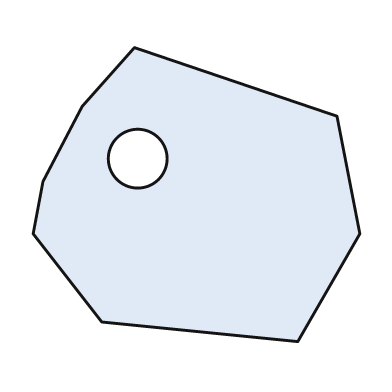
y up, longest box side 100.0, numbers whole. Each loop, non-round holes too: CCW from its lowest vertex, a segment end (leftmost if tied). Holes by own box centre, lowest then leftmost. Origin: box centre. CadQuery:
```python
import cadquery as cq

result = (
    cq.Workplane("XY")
    .moveTo(31.0, -45.0)
    .lineTo(50.0, -12.0)
    .lineTo(43.0, 24.0)
    .lineTo(-19.0, 45.0)
    .lineTo(-35.0, 27.0)
    .lineTo(-47.0, 4.0)
    .lineTo(-50.0, -12.0)
    .lineTo(-29.0, -39.0)
    .close()
    .moveTo(-18.0, 11.0)
    .circle(9.0)
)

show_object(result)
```